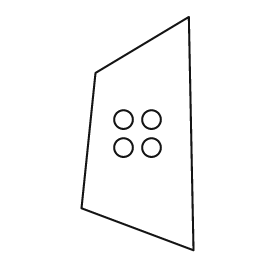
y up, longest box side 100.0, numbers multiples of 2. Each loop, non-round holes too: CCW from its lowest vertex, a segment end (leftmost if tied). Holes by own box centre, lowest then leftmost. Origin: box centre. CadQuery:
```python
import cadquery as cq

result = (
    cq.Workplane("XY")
    .moveTo(24.0, -50.0)
    .lineTo(22.0, 50.0)
    .lineTo(-18.0, 26.0)
    .lineTo(-24.0, -32.0)
    .close()
    .moveTo(-6.0, -6.0)
    .circle(4.0)
    .moveTo(6.0, -6.0)
    .circle(4.0)
    .moveTo(-6.0, 6.0)
    .circle(4.0)
    .moveTo(6.0, 6.0)
    .circle(4.0)
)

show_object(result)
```